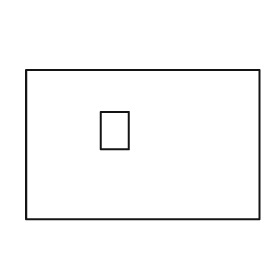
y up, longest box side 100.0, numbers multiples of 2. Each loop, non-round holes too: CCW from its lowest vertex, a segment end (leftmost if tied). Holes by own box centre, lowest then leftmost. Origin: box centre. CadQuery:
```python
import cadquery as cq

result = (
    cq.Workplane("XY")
    .moveTo(-50.0, -32.0)
    .lineTo(50.0, -32.0)
    .lineTo(50.0, 32.0)
    .lineTo(-50.0, 32.0)
    .close()
    .moveTo(-18.0, -2.0)
    .lineTo(-6.0, -2.0)
    .lineTo(-6.0, 14.0)
    .lineTo(-18.0, 14.0)
    .close()
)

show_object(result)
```